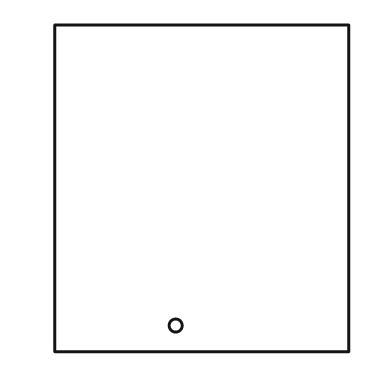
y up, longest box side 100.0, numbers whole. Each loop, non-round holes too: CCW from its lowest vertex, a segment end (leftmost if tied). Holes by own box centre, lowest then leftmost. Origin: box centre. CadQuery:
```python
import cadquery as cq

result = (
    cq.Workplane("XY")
    .moveTo(-45.0, -50.0)
    .lineTo(45.0, -50.0)
    .lineTo(45.0, 50.0)
    .lineTo(-45.0, 50.0)
    .close()
    .moveTo(-8.0, -42.0)
    .circle(2.0)
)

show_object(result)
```